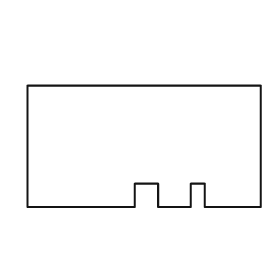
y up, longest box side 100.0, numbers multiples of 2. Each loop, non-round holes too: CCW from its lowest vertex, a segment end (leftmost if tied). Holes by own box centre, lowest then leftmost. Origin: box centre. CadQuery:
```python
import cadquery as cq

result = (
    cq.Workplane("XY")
    .moveTo(-50.0, -26.0)
    .lineTo(-4.0, -26.0)
    .lineTo(-4.0, -16.0)
    .lineTo(6.0, -16.0)
    .lineTo(6.0, -26.0)
    .lineTo(20.0, -26.0)
    .lineTo(20.0, -16.0)
    .lineTo(26.0, -16.0)
    .lineTo(26.0, -26.0)
    .lineTo(50.0, -26.0)
    .lineTo(50.0, 26.0)
    .lineTo(-50.0, 26.0)
    .close()
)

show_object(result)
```